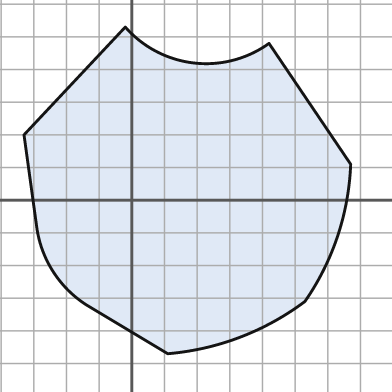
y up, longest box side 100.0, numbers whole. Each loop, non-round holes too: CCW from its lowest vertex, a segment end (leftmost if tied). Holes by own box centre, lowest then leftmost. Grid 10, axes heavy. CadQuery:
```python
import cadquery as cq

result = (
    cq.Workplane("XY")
    .moveTo(11.0, -47.0)
    .threePointArc((33.0, -42.0), (53.0, -31.0))
    .threePointArc((63.0, -11.0), (67.0, 11.0))
    .lineTo(42.0, 48.0)
    .threePointArc((19.0, 42.0), (-2.0, 53.0))
    .lineTo(-33.0, 20.0)
    .lineTo(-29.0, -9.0)
    .threePointArc((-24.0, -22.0), (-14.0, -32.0))
    .close()
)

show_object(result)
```